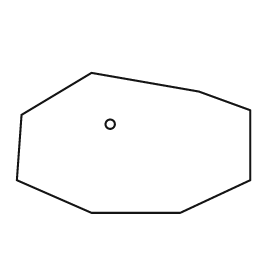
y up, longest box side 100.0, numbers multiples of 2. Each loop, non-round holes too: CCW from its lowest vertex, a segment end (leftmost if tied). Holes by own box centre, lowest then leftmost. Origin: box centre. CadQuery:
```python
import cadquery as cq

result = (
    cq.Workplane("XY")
    .moveTo(-18.0, -30.0)
    .lineTo(20.0, -30.0)
    .lineTo(50.0, -16.0)
    .lineTo(50.0, 14.0)
    .lineTo(28.0, 22.0)
    .lineTo(-18.0, 30.0)
    .lineTo(-48.0, 12.0)
    .lineTo(-50.0, -16.0)
    .close()
    .moveTo(-10.0, 8.0)
    .circle(2.0)
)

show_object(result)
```